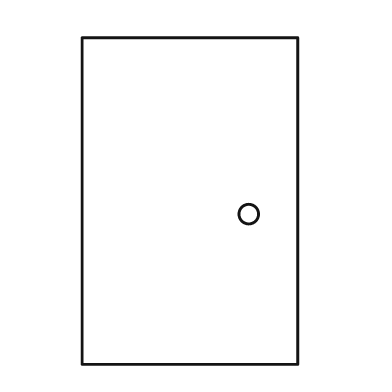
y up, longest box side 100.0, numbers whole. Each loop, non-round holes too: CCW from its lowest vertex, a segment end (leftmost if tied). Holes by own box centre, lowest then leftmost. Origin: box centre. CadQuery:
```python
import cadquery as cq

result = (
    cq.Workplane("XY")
    .moveTo(-33.0, -50.0)
    .lineTo(33.0, -50.0)
    .lineTo(33.0, 50.0)
    .lineTo(-33.0, 50.0)
    .close()
    .moveTo(18.0, -4.0)
    .circle(3.0)
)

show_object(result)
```